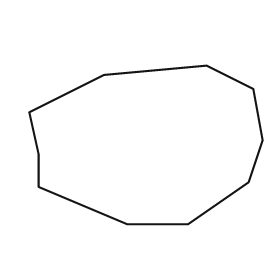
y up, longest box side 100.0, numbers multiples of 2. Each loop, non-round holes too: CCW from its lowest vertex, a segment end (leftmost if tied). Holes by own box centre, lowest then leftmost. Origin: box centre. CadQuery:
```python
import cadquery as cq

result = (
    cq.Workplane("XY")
    .moveTo(-8.0, -34.0)
    .lineTo(18.0, -34.0)
    .lineTo(44.0, -16.0)
    .lineTo(50.0, 2.0)
    .lineTo(46.0, 24.0)
    .lineTo(26.0, 34.0)
    .lineTo(-18.0, 30.0)
    .lineTo(-50.0, 14.0)
    .lineTo(-46.0, -4.0)
    .lineTo(-46.0, -18.0)
    .close()
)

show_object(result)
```